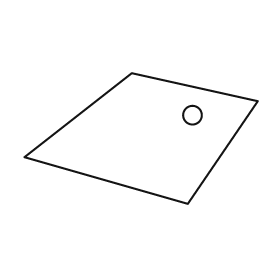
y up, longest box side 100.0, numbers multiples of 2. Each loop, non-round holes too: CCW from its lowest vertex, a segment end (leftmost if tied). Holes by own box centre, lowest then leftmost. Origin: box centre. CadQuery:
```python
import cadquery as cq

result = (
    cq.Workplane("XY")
    .moveTo(20.0, -28.0)
    .lineTo(50.0, 16.0)
    .lineTo(-4.0, 28.0)
    .lineTo(-50.0, -8.0)
    .close()
    .moveTo(22.0, 10.0)
    .circle(4.0)
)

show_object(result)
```